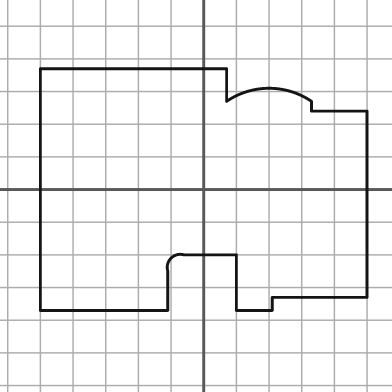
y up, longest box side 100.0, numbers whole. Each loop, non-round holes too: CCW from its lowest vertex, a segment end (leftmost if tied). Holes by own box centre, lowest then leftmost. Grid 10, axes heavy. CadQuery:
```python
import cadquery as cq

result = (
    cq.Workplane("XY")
    .moveTo(-50.0, -37.0)
    .lineTo(-11.0, -37.0)
    .lineTo(-11.0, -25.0)
    .threePointArc((-10.0, -21.0), (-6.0, -20.0))
    .lineTo(10.0, -20.0)
    .lineTo(10.0, -37.0)
    .lineTo(21.0, -37.0)
    .lineTo(21.0, -33.0)
    .lineTo(50.0, -33.0)
    .lineTo(50.0, 24.0)
    .lineTo(33.0, 24.0)
    .lineTo(33.0, 27.0)
    .threePointArc((20.0, 31.0), (7.0, 27.0))
    .lineTo(7.0, 37.0)
    .lineTo(-50.0, 37.0)
    .close()
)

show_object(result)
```